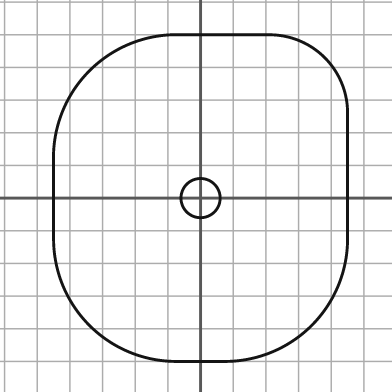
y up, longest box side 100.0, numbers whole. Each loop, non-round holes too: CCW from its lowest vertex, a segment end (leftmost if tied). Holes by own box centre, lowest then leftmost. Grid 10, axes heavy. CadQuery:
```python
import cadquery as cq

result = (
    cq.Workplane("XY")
    .moveTo(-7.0, -50.0)
    .lineTo(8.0, -50.0)
    .threePointArc((34.0, -39.0), (45.0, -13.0))
    .lineTo(45.0, 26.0)
    .threePointArc((38.0, 43.0), (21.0, 50.0))
    .lineTo(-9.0, 50.0)
    .threePointArc((-34.0, 39.0), (-45.0, 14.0))
    .lineTo(-45.0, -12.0)
    .threePointArc((-34.0, -39.0), (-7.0, -50.0))
    .close()
    .moveTo(0.0, 0.0)
    .circle(6.0)
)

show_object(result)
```